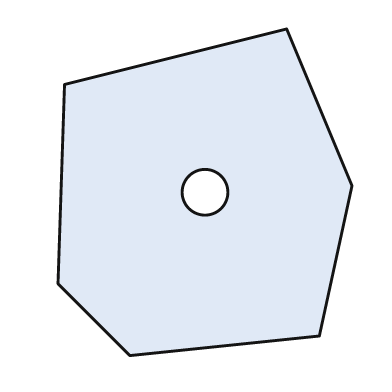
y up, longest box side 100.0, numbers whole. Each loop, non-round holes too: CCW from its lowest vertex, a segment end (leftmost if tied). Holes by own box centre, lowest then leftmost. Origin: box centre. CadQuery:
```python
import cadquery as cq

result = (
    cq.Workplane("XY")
    .moveTo(-23.0, -50.0)
    .lineTo(35.0, -44.0)
    .lineTo(45.0, 2.0)
    .lineTo(25.0, 50.0)
    .lineTo(-43.0, 33.0)
    .lineTo(-45.0, -28.0)
    .close()
    .moveTo(0.0, 0.0)
    .circle(7.0)
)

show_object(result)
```